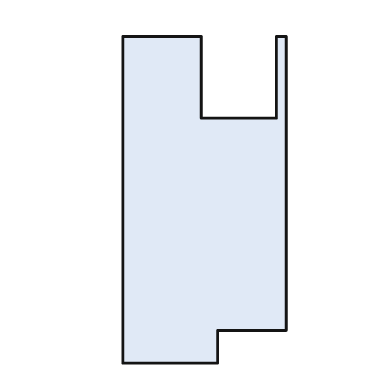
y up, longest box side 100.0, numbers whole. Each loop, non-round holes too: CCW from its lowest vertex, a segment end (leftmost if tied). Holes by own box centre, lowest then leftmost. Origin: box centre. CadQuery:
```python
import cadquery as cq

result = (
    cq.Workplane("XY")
    .moveTo(-25.0, -50.0)
    .lineTo(4.0, -50.0)
    .lineTo(4.0, -40.0)
    .lineTo(25.0, -40.0)
    .lineTo(25.0, 50.0)
    .lineTo(22.0, 50.0)
    .lineTo(22.0, 25.0)
    .lineTo(-1.0, 25.0)
    .lineTo(-1.0, 50.0)
    .lineTo(-25.0, 50.0)
    .close()
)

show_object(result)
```